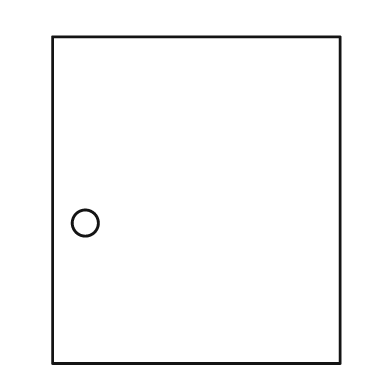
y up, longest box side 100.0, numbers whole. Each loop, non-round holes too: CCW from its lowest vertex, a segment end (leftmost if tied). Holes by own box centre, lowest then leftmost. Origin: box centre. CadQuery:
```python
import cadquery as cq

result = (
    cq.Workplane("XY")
    .moveTo(-44.0, -50.0)
    .lineTo(44.0, -50.0)
    .lineTo(44.0, 50.0)
    .lineTo(-44.0, 50.0)
    .close()
    .moveTo(-34.0, -7.0)
    .circle(4.0)
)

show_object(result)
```